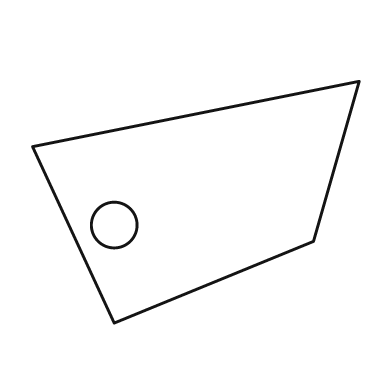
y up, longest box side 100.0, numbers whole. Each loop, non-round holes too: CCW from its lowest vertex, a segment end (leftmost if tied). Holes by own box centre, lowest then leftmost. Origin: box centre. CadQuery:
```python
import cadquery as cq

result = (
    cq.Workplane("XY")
    .moveTo(-25.0, -37.0)
    .lineTo(36.0, -12.0)
    .lineTo(50.0, 37.0)
    .lineTo(-50.0, 17.0)
    .close()
    .moveTo(-25.0, -7.0)
    .circle(7.0)
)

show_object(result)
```